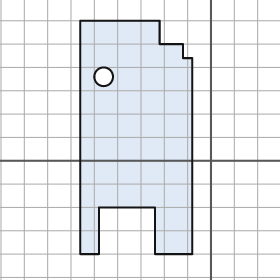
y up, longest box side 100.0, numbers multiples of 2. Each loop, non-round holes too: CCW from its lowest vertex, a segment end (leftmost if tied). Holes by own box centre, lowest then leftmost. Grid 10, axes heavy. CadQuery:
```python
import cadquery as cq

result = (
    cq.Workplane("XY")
    .moveTo(-56.0, -40.0)
    .lineTo(-48.0, -40.0)
    .lineTo(-48.0, -20.0)
    .lineTo(-24.0, -20.0)
    .lineTo(-24.0, -40.0)
    .lineTo(-8.0, -40.0)
    .lineTo(-8.0, 44.0)
    .lineTo(-12.0, 44.0)
    .lineTo(-12.0, 50.0)
    .lineTo(-22.0, 50.0)
    .lineTo(-22.0, 60.0)
    .lineTo(-56.0, 60.0)
    .close()
    .moveTo(-46.0, 36.0)
    .circle(4.0)
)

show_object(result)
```